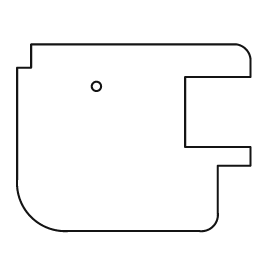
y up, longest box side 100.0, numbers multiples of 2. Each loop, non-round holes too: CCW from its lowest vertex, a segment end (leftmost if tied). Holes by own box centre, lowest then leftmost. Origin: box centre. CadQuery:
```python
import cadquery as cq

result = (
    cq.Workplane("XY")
    .moveTo(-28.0, -40.0)
    .lineTo(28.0, -40.0)
    .threePointArc((34.0, -38.0), (36.0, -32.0))
    .lineTo(36.0, -12.0)
    .lineTo(50.0, -12.0)
    .lineTo(50.0, -4.0)
    .lineTo(22.0, -4.0)
    .lineTo(22.0, 26.0)
    .lineTo(50.0, 26.0)
    .lineTo(50.0, 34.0)
    .threePointArc((48.0, 38.0), (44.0, 40.0))
    .lineTo(-44.0, 40.0)
    .lineTo(-44.0, 30.0)
    .lineTo(-50.0, 30.0)
    .lineTo(-50.0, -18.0)
    .threePointArc((-44.0, -34.0), (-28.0, -40.0))
    .close()
    .moveTo(-16.0, 22.0)
    .circle(2.0)
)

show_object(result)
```